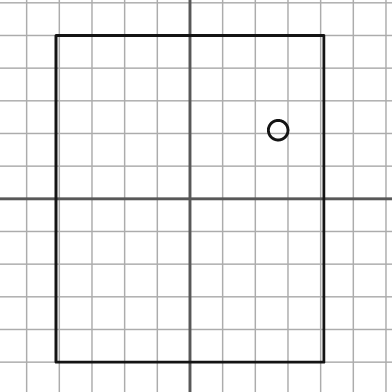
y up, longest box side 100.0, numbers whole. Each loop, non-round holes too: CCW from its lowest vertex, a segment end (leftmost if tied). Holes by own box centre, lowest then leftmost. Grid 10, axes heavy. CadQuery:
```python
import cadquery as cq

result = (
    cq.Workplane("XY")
    .moveTo(-41.0, -50.0)
    .lineTo(41.0, -50.0)
    .lineTo(41.0, 50.0)
    .lineTo(-41.0, 50.0)
    .close()
    .moveTo(27.0, 21.0)
    .circle(3.0)
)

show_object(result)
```